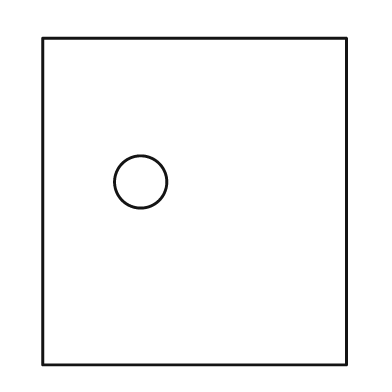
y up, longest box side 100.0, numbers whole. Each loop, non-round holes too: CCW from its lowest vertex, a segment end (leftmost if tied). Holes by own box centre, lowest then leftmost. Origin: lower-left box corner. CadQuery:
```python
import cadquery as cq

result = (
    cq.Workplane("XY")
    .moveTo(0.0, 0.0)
    .lineTo(93.0, 0.0)
    .lineTo(93.0, 100.0)
    .lineTo(0.0, 100.0)
    .close()
    .moveTo(30.0, 56.0)
    .circle(8.0)
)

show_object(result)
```